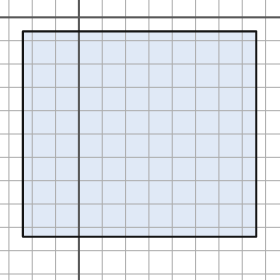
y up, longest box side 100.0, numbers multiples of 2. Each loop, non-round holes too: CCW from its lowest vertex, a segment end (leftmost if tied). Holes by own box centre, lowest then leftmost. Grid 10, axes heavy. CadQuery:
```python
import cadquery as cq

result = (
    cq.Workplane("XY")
    .moveTo(-24.0, -94.0)
    .lineTo(76.0, -94.0)
    .lineTo(76.0, -6.0)
    .lineTo(-24.0, -6.0)
    .close()
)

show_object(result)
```